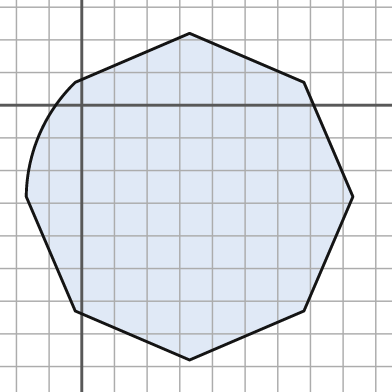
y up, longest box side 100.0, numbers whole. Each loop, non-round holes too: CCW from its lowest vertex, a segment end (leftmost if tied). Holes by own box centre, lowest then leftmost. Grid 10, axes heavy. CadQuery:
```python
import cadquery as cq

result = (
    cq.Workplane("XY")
    .moveTo(33.0, -78.0)
    .lineTo(68.0, -63.0)
    .lineTo(83.0, -28.0)
    .lineTo(68.0, 7.0)
    .lineTo(33.0, 22.0)
    .lineTo(-2.0, 7.0)
    .threePointArc((-13.0, -9.0), (-17.0, -28.0))
    .lineTo(-2.0, -63.0)
    .close()
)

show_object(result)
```